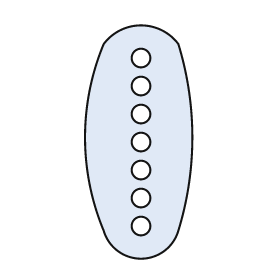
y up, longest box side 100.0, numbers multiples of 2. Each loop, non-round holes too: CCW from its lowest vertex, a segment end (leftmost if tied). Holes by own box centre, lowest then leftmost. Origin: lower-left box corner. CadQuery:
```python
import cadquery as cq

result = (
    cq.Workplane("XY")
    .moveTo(8.0, 12.0)
    .threePointArc((24.0, 0.0), (40.0, 12.0))
    .threePointArc((46.0, 52.0), (40.0, 92.0))
    .threePointArc((24.0, 100.0), (8.0, 92.0))
    .threePointArc((0.0, 52.0), (8.0, 12.0))
    .close()
    .moveTo(24.0, 14.0)
    .circle(4.0)
    .moveTo(24.0, 26.0)
    .circle(4.0)
    .moveTo(24.0, 38.0)
    .circle(4.0)
    .moveTo(24.0, 50.0)
    .circle(4.0)
    .moveTo(24.0, 62.0)
    .circle(4.0)
    .moveTo(24.0, 74.0)
    .circle(4.0)
    .moveTo(24.0, 86.0)
    .circle(4.0)
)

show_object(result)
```